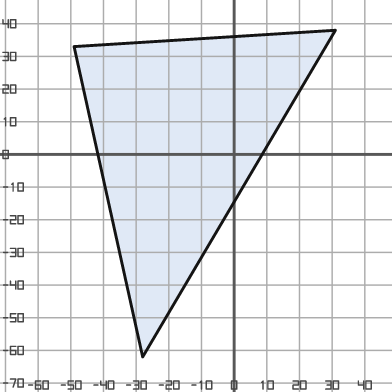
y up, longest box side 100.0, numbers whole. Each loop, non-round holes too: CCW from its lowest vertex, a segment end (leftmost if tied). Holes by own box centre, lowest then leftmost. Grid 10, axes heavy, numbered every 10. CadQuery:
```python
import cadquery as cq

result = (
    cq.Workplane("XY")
    .moveTo(-28.0, -62.0)
    .lineTo(31.0, 38.0)
    .lineTo(-49.0, 33.0)
    .close()
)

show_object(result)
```